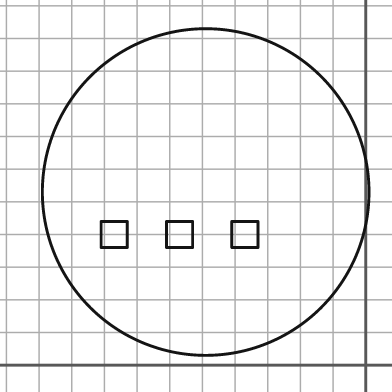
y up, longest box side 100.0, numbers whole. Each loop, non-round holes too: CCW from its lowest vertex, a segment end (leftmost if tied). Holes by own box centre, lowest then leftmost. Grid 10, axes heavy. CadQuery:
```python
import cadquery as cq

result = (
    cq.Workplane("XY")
    .moveTo(-49.0, 53.0)
    .circle(50.0)
    .moveTo(-81.0, 36.0)
    .lineTo(-73.0, 36.0)
    .lineTo(-73.0, 44.0)
    .lineTo(-81.0, 44.0)
    .close()
    .moveTo(-61.0, 36.0)
    .lineTo(-53.0, 36.0)
    .lineTo(-53.0, 44.0)
    .lineTo(-61.0, 44.0)
    .close()
    .moveTo(-41.0, 36.0)
    .lineTo(-33.0, 36.0)
    .lineTo(-33.0, 44.0)
    .lineTo(-41.0, 44.0)
    .close()
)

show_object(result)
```